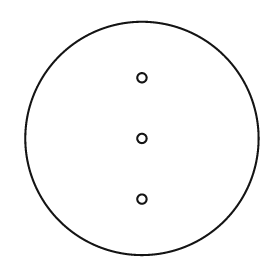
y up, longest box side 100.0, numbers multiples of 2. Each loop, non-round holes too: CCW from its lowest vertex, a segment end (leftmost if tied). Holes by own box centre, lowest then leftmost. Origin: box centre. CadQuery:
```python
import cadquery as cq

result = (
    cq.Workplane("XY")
    .moveTo(0.0, 0.0)
    .circle(50.0)
    .moveTo(0.0, -26.0)
    .circle(2.0)
    .moveTo(0.0, 0.0)
    .circle(2.0)
    .moveTo(0.0, 26.0)
    .circle(2.0)
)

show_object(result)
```